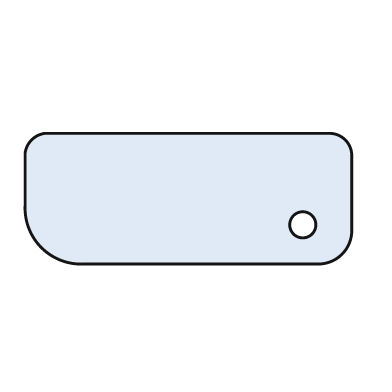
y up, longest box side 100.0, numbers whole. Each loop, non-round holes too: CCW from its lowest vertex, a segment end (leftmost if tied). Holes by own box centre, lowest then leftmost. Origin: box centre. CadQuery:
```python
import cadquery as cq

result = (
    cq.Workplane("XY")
    .moveTo(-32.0, -20.0)
    .lineTo(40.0, -20.0)
    .threePointArc((47.0, -17.0), (50.0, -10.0))
    .lineTo(50.0, 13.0)
    .threePointArc((48.0, 18.0), (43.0, 20.0))
    .lineTo(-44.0, 20.0)
    .threePointArc((-48.0, 18.0), (-50.0, 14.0))
    .lineTo(-50.0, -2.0)
    .threePointArc((-45.0, -15.0), (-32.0, -20.0))
    .close()
    .moveTo(35.0, -8.0)
    .circle(4.0)
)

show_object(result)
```